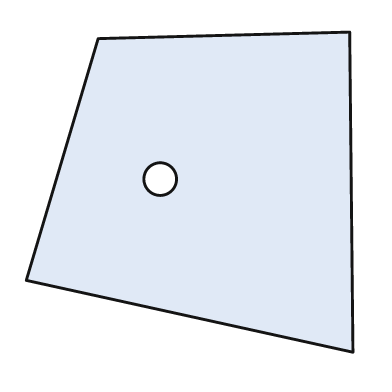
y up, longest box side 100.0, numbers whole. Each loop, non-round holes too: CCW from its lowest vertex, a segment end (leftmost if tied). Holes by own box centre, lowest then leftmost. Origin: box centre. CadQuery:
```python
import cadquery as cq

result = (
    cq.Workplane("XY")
    .moveTo(50.0, -49.0)
    .lineTo(49.0, 49.0)
    .lineTo(-28.0, 47.0)
    .lineTo(-50.0, -27.0)
    .close()
    .moveTo(-9.0, 4.0)
    .circle(5.0)
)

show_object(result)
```